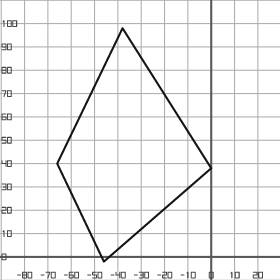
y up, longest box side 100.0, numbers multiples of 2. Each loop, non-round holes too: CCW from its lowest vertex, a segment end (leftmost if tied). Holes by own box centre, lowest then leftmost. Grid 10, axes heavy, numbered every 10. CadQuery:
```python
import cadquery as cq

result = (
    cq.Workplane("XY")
    .moveTo(-46.0, -2.0)
    .lineTo(0.0, 38.0)
    .lineTo(-38.0, 98.0)
    .lineTo(-66.0, 40.0)
    .close()
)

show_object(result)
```